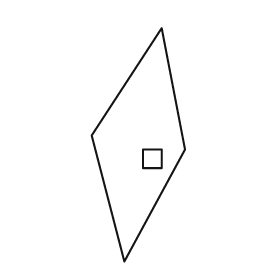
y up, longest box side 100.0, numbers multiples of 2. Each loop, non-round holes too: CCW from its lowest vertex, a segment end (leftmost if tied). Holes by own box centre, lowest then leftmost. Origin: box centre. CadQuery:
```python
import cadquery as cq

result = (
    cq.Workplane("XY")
    .moveTo(-6.0, -50.0)
    .lineTo(20.0, -2.0)
    .lineTo(10.0, 50.0)
    .lineTo(-20.0, 4.0)
    .close()
    .moveTo(2.0, -10.0)
    .lineTo(10.0, -10.0)
    .lineTo(10.0, -2.0)
    .lineTo(2.0, -2.0)
    .close()
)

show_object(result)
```